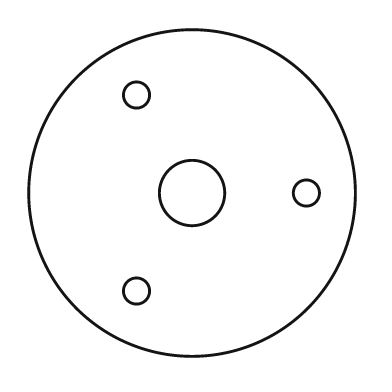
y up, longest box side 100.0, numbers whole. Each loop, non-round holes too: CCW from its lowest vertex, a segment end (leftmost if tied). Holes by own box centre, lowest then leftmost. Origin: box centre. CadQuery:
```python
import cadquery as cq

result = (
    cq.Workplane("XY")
    .moveTo(0.0, 0.0)
    .circle(50.0)
    .moveTo(-17.0, -30.0)
    .circle(4.0)
    .moveTo(0.0, 0.0)
    .circle(10.0)
    .moveTo(35.0, 0.0)
    .circle(4.0)
    .moveTo(-17.0, 30.0)
    .circle(4.0)
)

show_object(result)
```